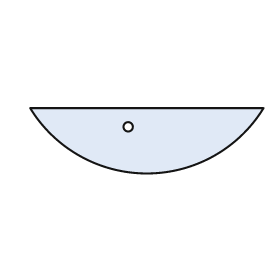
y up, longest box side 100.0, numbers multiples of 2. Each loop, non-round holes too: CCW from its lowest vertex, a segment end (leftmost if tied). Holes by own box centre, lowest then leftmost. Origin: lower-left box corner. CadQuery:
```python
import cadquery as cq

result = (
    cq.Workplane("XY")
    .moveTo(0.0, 28.0)
    .threePointArc((50.0, 0.0), (100.0, 28.0))
    .close()
    .moveTo(42.0, 20.0)
    .circle(2.0)
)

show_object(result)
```